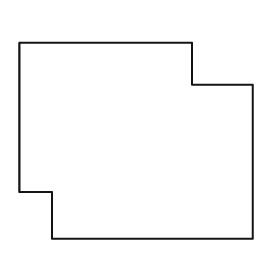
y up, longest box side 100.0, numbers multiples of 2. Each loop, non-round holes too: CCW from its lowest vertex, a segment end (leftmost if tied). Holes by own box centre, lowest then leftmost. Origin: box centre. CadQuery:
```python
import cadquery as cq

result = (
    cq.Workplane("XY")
    .moveTo(-36.0, -42.0)
    .lineTo(50.0, -42.0)
    .lineTo(50.0, 24.0)
    .lineTo(24.0, 24.0)
    .lineTo(24.0, 42.0)
    .lineTo(-50.0, 42.0)
    .lineTo(-50.0, -22.0)
    .lineTo(-36.0, -22.0)
    .close()
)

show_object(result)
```